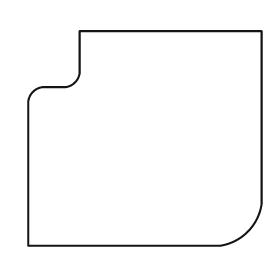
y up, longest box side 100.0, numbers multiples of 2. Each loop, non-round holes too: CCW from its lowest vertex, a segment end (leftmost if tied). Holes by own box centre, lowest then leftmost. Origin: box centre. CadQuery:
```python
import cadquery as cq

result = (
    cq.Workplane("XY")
    .moveTo(-50.0, -46.0)
    .lineTo(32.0, -46.0)
    .threePointArc((44.0, -40.0), (50.0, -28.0))
    .lineTo(50.0, 46.0)
    .lineTo(-28.0, 46.0)
    .lineTo(-28.0, 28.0)
    .threePointArc((-30.0, 24.0), (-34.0, 22.0))
    .lineTo(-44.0, 22.0)
    .threePointArc((-48.0, 20.0), (-50.0, 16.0))
    .close()
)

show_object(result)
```